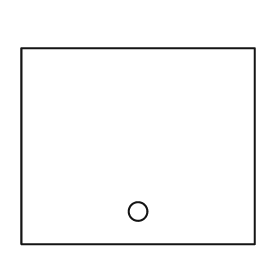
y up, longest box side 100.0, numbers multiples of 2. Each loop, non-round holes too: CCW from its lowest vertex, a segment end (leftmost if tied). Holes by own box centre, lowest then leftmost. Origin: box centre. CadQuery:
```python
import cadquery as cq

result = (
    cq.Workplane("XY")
    .moveTo(-50.0, -42.0)
    .lineTo(50.0, -42.0)
    .lineTo(50.0, 42.0)
    .lineTo(-50.0, 42.0)
    .close()
    .moveTo(0.0, -28.0)
    .circle(4.0)
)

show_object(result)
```